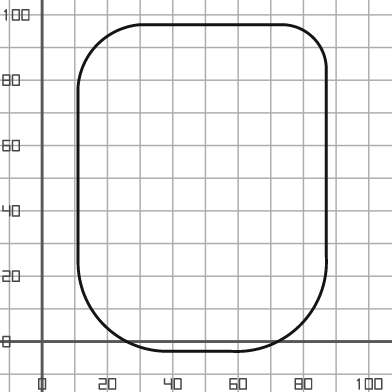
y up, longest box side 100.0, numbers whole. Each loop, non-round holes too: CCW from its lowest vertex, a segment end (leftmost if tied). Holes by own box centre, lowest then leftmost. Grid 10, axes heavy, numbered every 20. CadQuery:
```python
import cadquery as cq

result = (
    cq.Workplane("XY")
    .moveTo(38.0, -3.0)
    .lineTo(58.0, -3.0)
    .threePointArc((79.0, 5.0), (87.0, 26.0))
    .lineTo(87.0, 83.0)
    .threePointArc((83.0, 93.0), (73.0, 97.0))
    .lineTo(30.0, 97.0)
    .threePointArc((17.0, 91.0), (11.0, 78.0))
    .lineTo(11.0, 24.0)
    .threePointArc((19.0, 5.0), (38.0, -3.0))
    .close()
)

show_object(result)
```